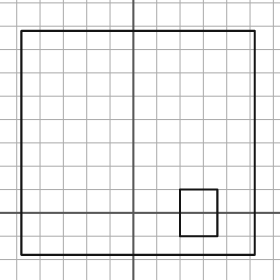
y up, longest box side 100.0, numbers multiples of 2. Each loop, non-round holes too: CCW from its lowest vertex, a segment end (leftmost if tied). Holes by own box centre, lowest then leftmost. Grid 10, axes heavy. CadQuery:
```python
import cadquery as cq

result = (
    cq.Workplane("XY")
    .moveTo(-48.0, -18.0)
    .lineTo(52.0, -18.0)
    .lineTo(52.0, 78.0)
    .lineTo(-48.0, 78.0)
    .close()
    .moveTo(20.0, -10.0)
    .lineTo(36.0, -10.0)
    .lineTo(36.0, 10.0)
    .lineTo(20.0, 10.0)
    .close()
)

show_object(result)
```